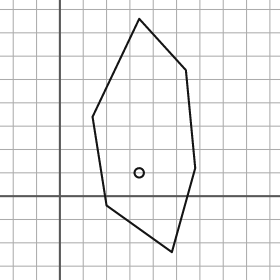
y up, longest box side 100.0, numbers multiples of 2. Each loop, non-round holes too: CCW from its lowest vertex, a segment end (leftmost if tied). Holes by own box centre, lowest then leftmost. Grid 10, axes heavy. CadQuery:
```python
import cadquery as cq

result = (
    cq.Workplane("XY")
    .moveTo(48.0, -24.0)
    .lineTo(58.0, 12.0)
    .lineTo(54.0, 54.0)
    .lineTo(34.0, 76.0)
    .lineTo(14.0, 34.0)
    .lineTo(20.0, -4.0)
    .close()
    .moveTo(34.0, 10.0)
    .circle(2.0)
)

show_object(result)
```